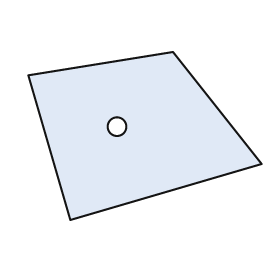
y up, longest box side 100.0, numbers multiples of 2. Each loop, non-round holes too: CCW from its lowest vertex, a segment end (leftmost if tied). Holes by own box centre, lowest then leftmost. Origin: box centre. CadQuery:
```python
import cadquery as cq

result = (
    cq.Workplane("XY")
    .moveTo(-32.0, -36.0)
    .lineTo(50.0, -12.0)
    .lineTo(12.0, 36.0)
    .lineTo(-50.0, 26.0)
    .close()
    .moveTo(-12.0, 4.0)
    .circle(4.0)
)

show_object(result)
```